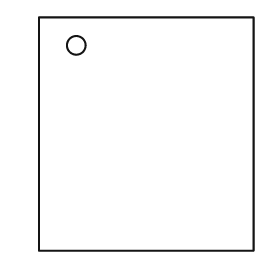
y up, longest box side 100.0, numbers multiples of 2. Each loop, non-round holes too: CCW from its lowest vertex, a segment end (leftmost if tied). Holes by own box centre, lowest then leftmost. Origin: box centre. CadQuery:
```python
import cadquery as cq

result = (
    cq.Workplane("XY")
    .moveTo(-46.0, -50.0)
    .lineTo(46.0, -50.0)
    .lineTo(46.0, 50.0)
    .lineTo(-46.0, 50.0)
    .close()
    .moveTo(-30.0, 38.0)
    .circle(4.0)
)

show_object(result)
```